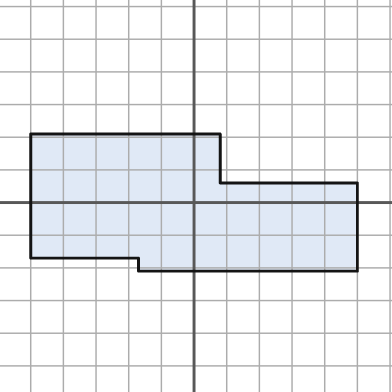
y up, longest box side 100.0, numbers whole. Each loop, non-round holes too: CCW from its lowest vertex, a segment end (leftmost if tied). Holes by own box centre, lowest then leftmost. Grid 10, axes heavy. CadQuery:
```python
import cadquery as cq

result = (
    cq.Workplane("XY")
    .moveTo(-17.0, -21.0)
    .lineTo(50.0, -21.0)
    .lineTo(50.0, 6.0)
    .lineTo(8.0, 6.0)
    .lineTo(8.0, 21.0)
    .lineTo(-50.0, 21.0)
    .lineTo(-50.0, -17.0)
    .lineTo(-17.0, -17.0)
    .close()
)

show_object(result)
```